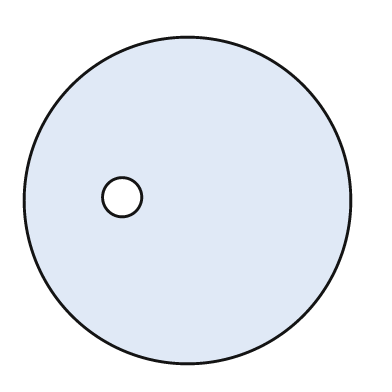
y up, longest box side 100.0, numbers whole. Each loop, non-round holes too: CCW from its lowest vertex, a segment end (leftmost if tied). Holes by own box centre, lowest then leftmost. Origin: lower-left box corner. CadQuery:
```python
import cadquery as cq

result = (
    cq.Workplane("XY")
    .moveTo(50.0, 50.0)
    .circle(50.0)
    .moveTo(30.0, 51.0)
    .circle(6.0)
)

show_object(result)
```